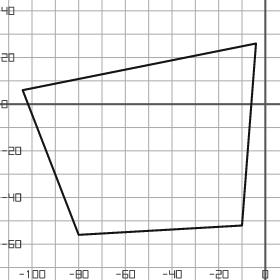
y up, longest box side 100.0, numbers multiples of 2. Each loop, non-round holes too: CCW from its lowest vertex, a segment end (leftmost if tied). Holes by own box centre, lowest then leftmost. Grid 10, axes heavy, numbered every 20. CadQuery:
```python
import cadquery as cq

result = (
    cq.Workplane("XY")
    .moveTo(-80.0, -56.0)
    .lineTo(-10.0, -52.0)
    .lineTo(-4.0, 26.0)
    .lineTo(-104.0, 6.0)
    .close()
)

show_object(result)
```